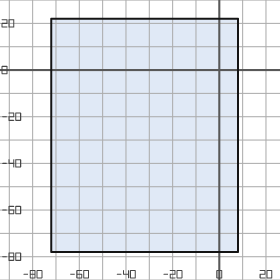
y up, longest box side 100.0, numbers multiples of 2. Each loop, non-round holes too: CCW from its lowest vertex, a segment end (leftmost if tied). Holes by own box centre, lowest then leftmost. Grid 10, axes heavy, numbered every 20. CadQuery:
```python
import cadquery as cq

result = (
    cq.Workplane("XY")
    .moveTo(-72.0, -78.0)
    .lineTo(8.0, -78.0)
    .lineTo(8.0, 22.0)
    .lineTo(-72.0, 22.0)
    .close()
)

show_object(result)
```